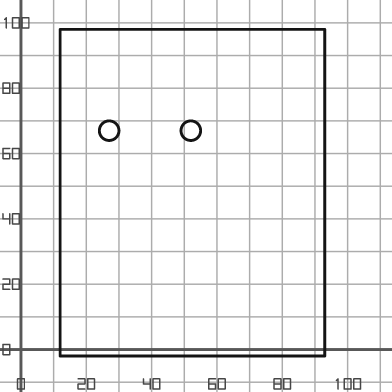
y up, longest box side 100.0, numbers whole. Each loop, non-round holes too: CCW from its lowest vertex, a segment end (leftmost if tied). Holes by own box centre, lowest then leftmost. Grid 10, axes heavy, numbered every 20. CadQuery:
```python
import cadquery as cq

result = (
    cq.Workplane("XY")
    .moveTo(12.0, -2.0)
    .lineTo(93.0, -2.0)
    .lineTo(93.0, 98.0)
    .lineTo(12.0, 98.0)
    .close()
    .moveTo(27.0, 67.0)
    .circle(3.0)
    .moveTo(52.0, 67.0)
    .circle(3.0)
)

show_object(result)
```